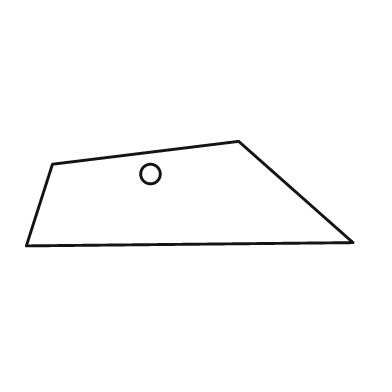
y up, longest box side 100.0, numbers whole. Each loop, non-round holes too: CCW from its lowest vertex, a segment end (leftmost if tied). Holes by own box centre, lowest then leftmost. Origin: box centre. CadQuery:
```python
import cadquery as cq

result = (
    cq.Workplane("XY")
    .moveTo(-50.0, -16.0)
    .lineTo(50.0, -15.0)
    .lineTo(15.0, 16.0)
    .lineTo(-42.0, 9.0)
    .close()
    .moveTo(-12.0, 6.0)
    .circle(3.0)
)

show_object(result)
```